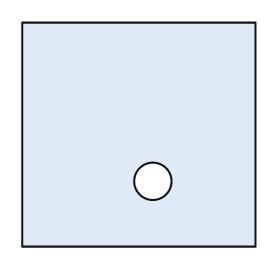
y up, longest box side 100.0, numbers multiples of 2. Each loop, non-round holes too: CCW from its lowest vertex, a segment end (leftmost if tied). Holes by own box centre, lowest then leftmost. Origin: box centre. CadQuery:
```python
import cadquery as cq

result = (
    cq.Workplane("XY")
    .moveTo(-50.0, -48.0)
    .lineTo(50.0, -48.0)
    .lineTo(50.0, 48.0)
    .lineTo(-50.0, 48.0)
    .close()
    .moveTo(6.0, -20.0)
    .circle(8.0)
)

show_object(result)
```